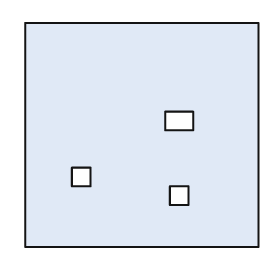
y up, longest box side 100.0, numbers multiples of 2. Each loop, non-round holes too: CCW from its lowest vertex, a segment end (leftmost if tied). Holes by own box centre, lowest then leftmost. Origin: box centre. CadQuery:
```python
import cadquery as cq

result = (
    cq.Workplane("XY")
    .moveTo(-50.0, -48.0)
    .lineTo(50.0, -48.0)
    .lineTo(50.0, 48.0)
    .lineTo(-50.0, 48.0)
    .close()
    .moveTo(12.0, -30.0)
    .lineTo(20.0, -30.0)
    .lineTo(20.0, -22.0)
    .lineTo(12.0, -22.0)
    .close()
    .moveTo(-30.0, -22.0)
    .lineTo(-22.0, -22.0)
    .lineTo(-22.0, -14.0)
    .lineTo(-30.0, -14.0)
    .close()
    .moveTo(10.0, 2.0)
    .lineTo(22.0, 2.0)
    .lineTo(22.0, 10.0)
    .lineTo(10.0, 10.0)
    .close()
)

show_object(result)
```